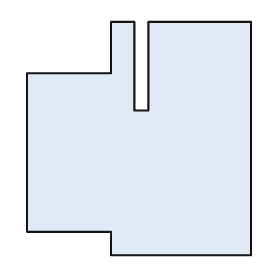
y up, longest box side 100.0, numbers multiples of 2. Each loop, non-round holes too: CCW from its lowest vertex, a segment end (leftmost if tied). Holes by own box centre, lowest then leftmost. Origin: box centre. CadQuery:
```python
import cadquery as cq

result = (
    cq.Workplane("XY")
    .moveTo(-12.0, -50.0)
    .lineTo(48.0, -50.0)
    .lineTo(48.0, 50.0)
    .lineTo(4.0, 50.0)
    .lineTo(4.0, 12.0)
    .lineTo(-2.0, 12.0)
    .lineTo(-2.0, 50.0)
    .lineTo(-12.0, 50.0)
    .lineTo(-12.0, 28.0)
    .lineTo(-48.0, 28.0)
    .lineTo(-48.0, -40.0)
    .lineTo(-12.0, -40.0)
    .close()
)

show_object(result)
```